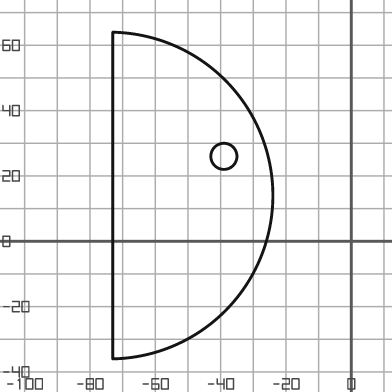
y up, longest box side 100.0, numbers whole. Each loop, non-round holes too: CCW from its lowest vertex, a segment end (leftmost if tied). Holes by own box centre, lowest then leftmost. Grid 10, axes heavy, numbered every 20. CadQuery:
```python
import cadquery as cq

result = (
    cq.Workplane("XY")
    .moveTo(-73.0, -36.0)
    .threePointArc((-24.0, 14.0), (-73.0, 64.0))
    .close()
    .moveTo(-39.0, 26.0)
    .circle(4.0)
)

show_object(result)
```